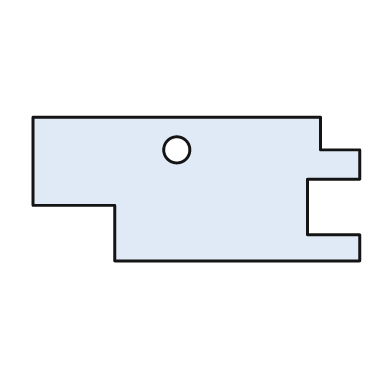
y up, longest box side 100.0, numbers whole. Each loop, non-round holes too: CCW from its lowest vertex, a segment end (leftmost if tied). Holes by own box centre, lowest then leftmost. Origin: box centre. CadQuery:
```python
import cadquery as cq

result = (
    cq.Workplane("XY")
    .moveTo(-25.0, -22.0)
    .lineTo(50.0, -22.0)
    .lineTo(50.0, -14.0)
    .lineTo(34.0, -14.0)
    .lineTo(34.0, 3.0)
    .lineTo(50.0, 3.0)
    .lineTo(50.0, 12.0)
    .lineTo(38.0, 12.0)
    .lineTo(38.0, 22.0)
    .lineTo(-50.0, 22.0)
    .lineTo(-50.0, -5.0)
    .lineTo(-25.0, -5.0)
    .close()
    .moveTo(-6.0, 12.0)
    .circle(4.0)
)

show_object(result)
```